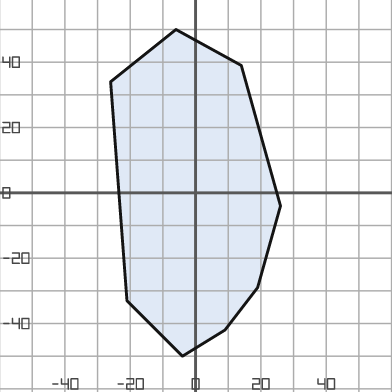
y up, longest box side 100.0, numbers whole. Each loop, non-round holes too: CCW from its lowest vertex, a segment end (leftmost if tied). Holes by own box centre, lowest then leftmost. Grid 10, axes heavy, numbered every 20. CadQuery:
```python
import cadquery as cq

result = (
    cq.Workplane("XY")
    .moveTo(-4.0, -50.0)
    .lineTo(9.0, -42.0)
    .lineTo(19.0, -29.0)
    .lineTo(26.0, -4.0)
    .lineTo(14.0, 39.0)
    .lineTo(-6.0, 50.0)
    .lineTo(-26.0, 34.0)
    .lineTo(-21.0, -33.0)
    .close()
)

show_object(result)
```